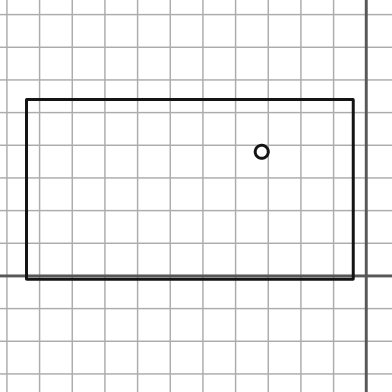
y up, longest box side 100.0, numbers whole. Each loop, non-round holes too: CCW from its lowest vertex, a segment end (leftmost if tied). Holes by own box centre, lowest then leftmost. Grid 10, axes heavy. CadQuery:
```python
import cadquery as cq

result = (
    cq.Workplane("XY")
    .moveTo(-104.0, -1.0)
    .lineTo(-4.0, -1.0)
    .lineTo(-4.0, 54.0)
    .lineTo(-104.0, 54.0)
    .close()
    .moveTo(-32.0, 38.0)
    .circle(2.0)
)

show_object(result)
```